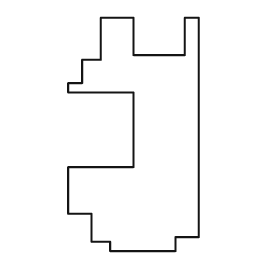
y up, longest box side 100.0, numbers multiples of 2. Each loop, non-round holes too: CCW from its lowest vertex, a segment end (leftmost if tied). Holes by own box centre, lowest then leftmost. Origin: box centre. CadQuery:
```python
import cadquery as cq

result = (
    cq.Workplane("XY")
    .moveTo(-10.0, -50.0)
    .lineTo(18.0, -50.0)
    .lineTo(18.0, -44.0)
    .lineTo(28.0, -44.0)
    .lineTo(28.0, 50.0)
    .lineTo(22.0, 50.0)
    .lineTo(22.0, 34.0)
    .lineTo(0.0, 34.0)
    .lineTo(0.0, 50.0)
    .lineTo(-14.0, 50.0)
    .lineTo(-14.0, 32.0)
    .lineTo(-22.0, 32.0)
    .lineTo(-22.0, 22.0)
    .lineTo(-28.0, 22.0)
    .lineTo(-28.0, 18.0)
    .lineTo(0.0, 18.0)
    .lineTo(0.0, -14.0)
    .lineTo(-28.0, -14.0)
    .lineTo(-28.0, -34.0)
    .lineTo(-18.0, -34.0)
    .lineTo(-18.0, -46.0)
    .lineTo(-10.0, -46.0)
    .close()
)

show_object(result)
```